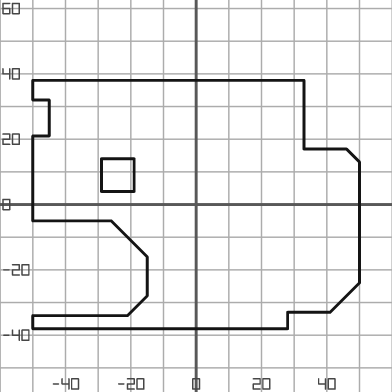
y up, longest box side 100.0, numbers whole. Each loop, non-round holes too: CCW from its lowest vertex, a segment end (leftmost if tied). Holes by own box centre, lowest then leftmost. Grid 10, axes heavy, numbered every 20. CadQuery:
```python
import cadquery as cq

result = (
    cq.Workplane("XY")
    .moveTo(-50.0, -38.0)
    .lineTo(28.0, -38.0)
    .lineTo(28.0, -33.0)
    .lineTo(41.0, -33.0)
    .lineTo(50.0, -24.0)
    .lineTo(50.0, 13.0)
    .lineTo(46.0, 17.0)
    .lineTo(33.0, 17.0)
    .lineTo(33.0, 38.0)
    .lineTo(-50.0, 38.0)
    .lineTo(-50.0, 32.0)
    .lineTo(-45.0, 32.0)
    .lineTo(-45.0, 21.0)
    .lineTo(-50.0, 21.0)
    .lineTo(-50.0, -5.0)
    .lineTo(-26.0, -5.0)
    .lineTo(-15.0, -16.0)
    .lineTo(-15.0, -28.0)
    .lineTo(-21.0, -34.0)
    .lineTo(-50.0, -34.0)
    .close()
    .moveTo(-29.0, 4.0)
    .lineTo(-19.0, 4.0)
    .lineTo(-19.0, 14.0)
    .lineTo(-29.0, 14.0)
    .close()
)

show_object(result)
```